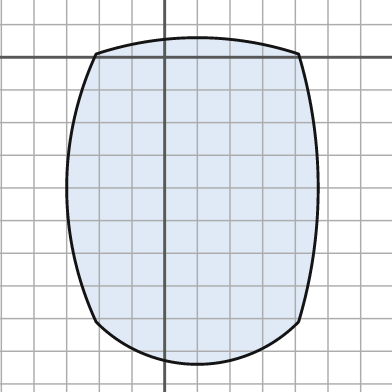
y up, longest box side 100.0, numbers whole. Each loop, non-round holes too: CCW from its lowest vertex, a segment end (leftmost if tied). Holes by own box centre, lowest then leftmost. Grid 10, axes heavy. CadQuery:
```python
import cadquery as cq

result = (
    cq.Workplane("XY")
    .moveTo(-21.0, -81.0)
    .threePointArc((10.0, -94.0), (41.0, -81.0))
    .threePointArc((47.0, -40.0), (41.0, 1.0))
    .threePointArc((10.0, 6.0), (-21.0, 1.0))
    .threePointArc((-30.0, -40.0), (-21.0, -81.0))
    .close()
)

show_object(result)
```